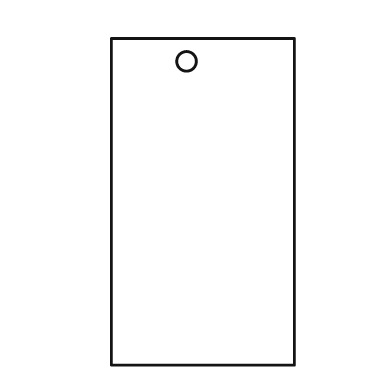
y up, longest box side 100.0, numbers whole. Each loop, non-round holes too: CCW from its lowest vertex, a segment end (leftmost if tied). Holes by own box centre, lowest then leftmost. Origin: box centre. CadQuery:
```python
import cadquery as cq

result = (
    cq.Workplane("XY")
    .moveTo(-28.0, -50.0)
    .lineTo(28.0, -50.0)
    .lineTo(28.0, 50.0)
    .lineTo(-28.0, 50.0)
    .close()
    .moveTo(-5.0, 43.0)
    .circle(3.0)
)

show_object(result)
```